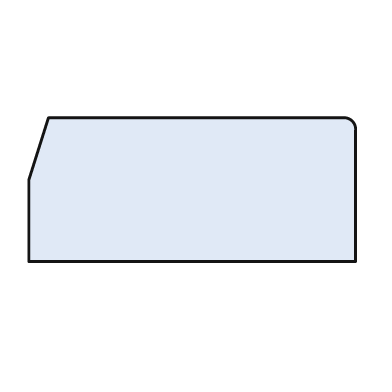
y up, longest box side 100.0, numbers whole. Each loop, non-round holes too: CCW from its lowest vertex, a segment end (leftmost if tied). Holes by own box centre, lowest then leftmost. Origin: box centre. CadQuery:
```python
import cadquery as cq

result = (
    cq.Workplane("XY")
    .moveTo(-50.0, -22.0)
    .lineTo(50.0, -22.0)
    .lineTo(50.0, 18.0)
    .threePointArc((49.0, 21.0), (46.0, 22.0))
    .lineTo(-44.0, 22.0)
    .lineTo(-50.0, 3.0)
    .close()
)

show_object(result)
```